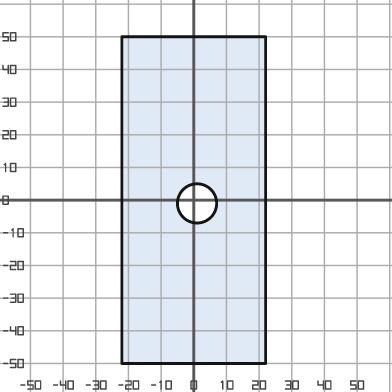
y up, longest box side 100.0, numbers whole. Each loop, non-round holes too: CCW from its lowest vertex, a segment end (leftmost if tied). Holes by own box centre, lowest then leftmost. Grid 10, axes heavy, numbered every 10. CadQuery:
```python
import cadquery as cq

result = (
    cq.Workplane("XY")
    .moveTo(-22.0, -50.0)
    .lineTo(22.0, -50.0)
    .lineTo(22.0, 50.0)
    .lineTo(-22.0, 50.0)
    .close()
    .moveTo(1.0, -1.0)
    .circle(6.0)
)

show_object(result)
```